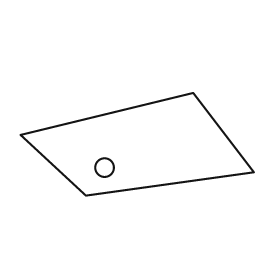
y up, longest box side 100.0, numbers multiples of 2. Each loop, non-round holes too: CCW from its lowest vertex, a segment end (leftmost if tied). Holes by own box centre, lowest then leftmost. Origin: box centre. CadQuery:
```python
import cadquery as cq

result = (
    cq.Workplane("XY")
    .moveTo(-22.0, -22.0)
    .lineTo(50.0, -12.0)
    .lineTo(24.0, 22.0)
    .lineTo(-50.0, 4.0)
    .close()
    .moveTo(-14.0, -10.0)
    .circle(4.0)
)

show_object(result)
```